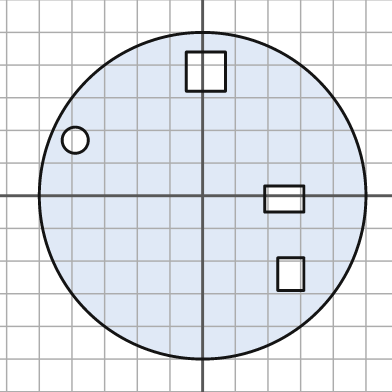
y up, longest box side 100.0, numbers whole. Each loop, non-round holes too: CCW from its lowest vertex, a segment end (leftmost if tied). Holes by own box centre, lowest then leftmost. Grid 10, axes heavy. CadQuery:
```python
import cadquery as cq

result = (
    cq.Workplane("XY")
    .moveTo(0.0, 0.0)
    .circle(50.0)
    .moveTo(23.0, -29.0)
    .lineTo(31.0, -29.0)
    .lineTo(31.0, -19.0)
    .lineTo(23.0, -19.0)
    .close()
    .moveTo(19.0, -5.0)
    .lineTo(31.0, -5.0)
    .lineTo(31.0, 3.0)
    .lineTo(19.0, 3.0)
    .close()
    .moveTo(-39.0, 17.0)
    .circle(4.0)
    .moveTo(-5.0, 32.0)
    .lineTo(7.0, 32.0)
    .lineTo(7.0, 44.0)
    .lineTo(-5.0, 44.0)
    .close()
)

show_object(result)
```